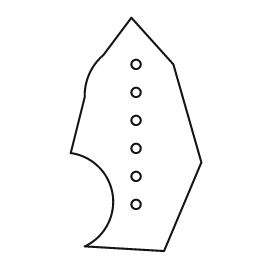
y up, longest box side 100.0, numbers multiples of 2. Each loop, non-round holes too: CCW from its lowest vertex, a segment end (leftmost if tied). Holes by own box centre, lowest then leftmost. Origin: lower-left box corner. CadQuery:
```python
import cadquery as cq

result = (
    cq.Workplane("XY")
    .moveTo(40.0, 0.0)
    .lineTo(56.0, 38.0)
    .lineTo(44.0, 80.0)
    .lineTo(26.0, 100.0)
    .lineTo(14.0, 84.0)
    .threePointArc((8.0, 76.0), (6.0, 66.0))
    .lineTo(0.0, 42.0)
    .threePointArc((18.0, 24.0), (6.0, 2.0))
    .close()
    .moveTo(28.0, 20.0)
    .circle(2.0)
    .moveTo(28.0, 32.0)
    .circle(2.0)
    .moveTo(28.0, 44.0)
    .circle(2.0)
    .moveTo(28.0, 56.0)
    .circle(2.0)
    .moveTo(28.0, 68.0)
    .circle(2.0)
    .moveTo(28.0, 80.0)
    .circle(2.0)
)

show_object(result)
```